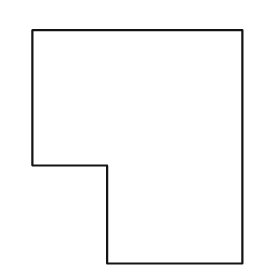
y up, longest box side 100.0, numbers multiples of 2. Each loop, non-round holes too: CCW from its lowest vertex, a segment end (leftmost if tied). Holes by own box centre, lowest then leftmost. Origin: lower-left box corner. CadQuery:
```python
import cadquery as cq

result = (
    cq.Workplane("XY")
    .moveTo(32.0, 0.0)
    .lineTo(90.0, 0.0)
    .lineTo(90.0, 100.0)
    .lineTo(0.0, 100.0)
    .lineTo(0.0, 42.0)
    .lineTo(32.0, 42.0)
    .close()
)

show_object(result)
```